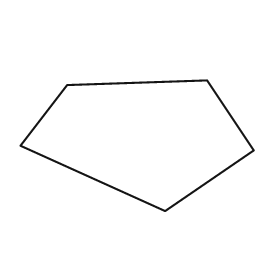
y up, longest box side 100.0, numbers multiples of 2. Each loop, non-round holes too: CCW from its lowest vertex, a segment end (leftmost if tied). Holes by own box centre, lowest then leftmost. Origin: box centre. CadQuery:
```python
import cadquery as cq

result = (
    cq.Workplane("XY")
    .moveTo(12.0, -28.0)
    .lineTo(50.0, -2.0)
    .lineTo(30.0, 28.0)
    .lineTo(-30.0, 26.0)
    .lineTo(-50.0, 0.0)
    .close()
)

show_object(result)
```